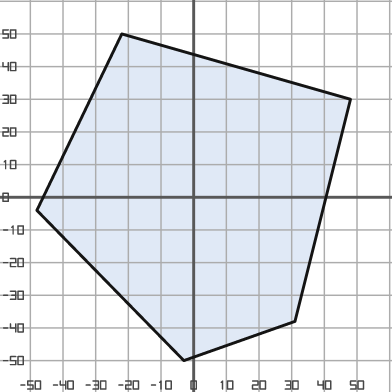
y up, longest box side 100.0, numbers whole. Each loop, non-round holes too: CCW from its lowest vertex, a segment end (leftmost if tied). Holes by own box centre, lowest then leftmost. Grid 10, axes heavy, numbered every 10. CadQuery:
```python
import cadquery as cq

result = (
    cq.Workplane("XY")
    .moveTo(-3.0, -50.0)
    .lineTo(31.0, -38.0)
    .lineTo(48.0, 30.0)
    .lineTo(-22.0, 50.0)
    .lineTo(-48.0, -4.0)
    .close()
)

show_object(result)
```